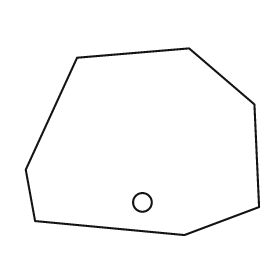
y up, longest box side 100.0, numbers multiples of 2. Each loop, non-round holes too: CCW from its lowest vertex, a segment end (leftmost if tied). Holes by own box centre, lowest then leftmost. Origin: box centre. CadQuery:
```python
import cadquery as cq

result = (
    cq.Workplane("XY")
    .moveTo(18.0, -40.0)
    .lineTo(50.0, -28.0)
    .lineTo(48.0, 16.0)
    .lineTo(20.0, 40.0)
    .lineTo(-28.0, 36.0)
    .lineTo(-50.0, -12.0)
    .lineTo(-46.0, -34.0)
    .close()
    .moveTo(0.0, -26.0)
    .circle(4.0)
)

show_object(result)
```